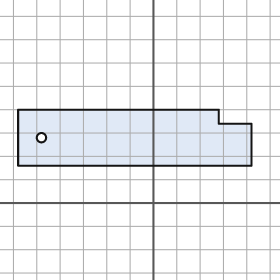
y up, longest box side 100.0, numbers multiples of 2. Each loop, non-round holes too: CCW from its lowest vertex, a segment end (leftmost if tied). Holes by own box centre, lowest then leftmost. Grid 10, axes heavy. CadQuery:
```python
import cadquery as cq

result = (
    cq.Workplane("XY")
    .moveTo(-58.0, 16.0)
    .lineTo(42.0, 16.0)
    .lineTo(42.0, 34.0)
    .lineTo(28.0, 34.0)
    .lineTo(28.0, 40.0)
    .lineTo(-58.0, 40.0)
    .close()
    .moveTo(-48.0, 28.0)
    .circle(2.0)
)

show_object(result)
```